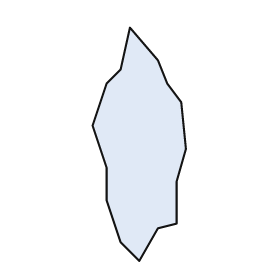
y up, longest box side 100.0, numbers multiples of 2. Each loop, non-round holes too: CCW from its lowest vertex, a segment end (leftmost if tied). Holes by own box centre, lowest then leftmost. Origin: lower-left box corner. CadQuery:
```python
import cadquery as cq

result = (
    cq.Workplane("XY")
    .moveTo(20.0, 0.0)
    .lineTo(28.0, 14.0)
    .lineTo(36.0, 16.0)
    .lineTo(36.0, 34.0)
    .lineTo(40.0, 48.0)
    .lineTo(38.0, 68.0)
    .lineTo(32.0, 76.0)
    .lineTo(28.0, 86.0)
    .lineTo(16.0, 100.0)
    .lineTo(12.0, 82.0)
    .lineTo(6.0, 76.0)
    .lineTo(0.0, 58.0)
    .lineTo(6.0, 40.0)
    .lineTo(6.0, 26.0)
    .lineTo(12.0, 8.0)
    .close()
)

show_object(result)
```